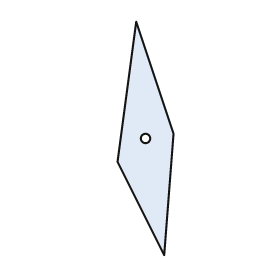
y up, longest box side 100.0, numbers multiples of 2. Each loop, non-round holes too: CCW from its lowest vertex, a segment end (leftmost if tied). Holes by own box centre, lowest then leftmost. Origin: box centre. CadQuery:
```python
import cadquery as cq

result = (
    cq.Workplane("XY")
    .moveTo(8.0, -50.0)
    .lineTo(12.0, 2.0)
    .lineTo(-4.0, 50.0)
    .lineTo(-12.0, -10.0)
    .close()
    .moveTo(0.0, 0.0)
    .circle(2.0)
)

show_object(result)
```